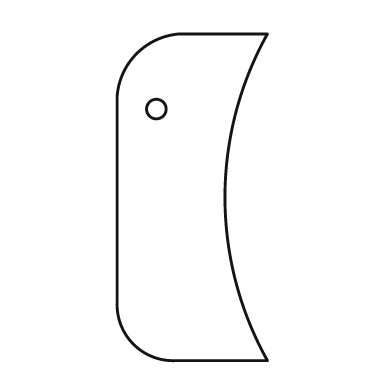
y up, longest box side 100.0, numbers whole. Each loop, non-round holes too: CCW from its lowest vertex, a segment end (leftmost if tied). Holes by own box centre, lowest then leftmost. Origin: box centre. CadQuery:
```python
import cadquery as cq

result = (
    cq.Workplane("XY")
    .moveTo(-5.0, -50.0)
    .lineTo(23.0, -50.0)
    .threePointArc((10.0, 0.0), (23.0, 50.0))
    .lineTo(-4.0, 50.0)
    .threePointArc((-17.0, 44.0), (-23.0, 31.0))
    .lineTo(-23.0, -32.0)
    .threePointArc((-18.0, -45.0), (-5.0, -50.0))
    .close()
    .moveTo(-11.0, 27.0)
    .circle(3.0)
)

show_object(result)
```